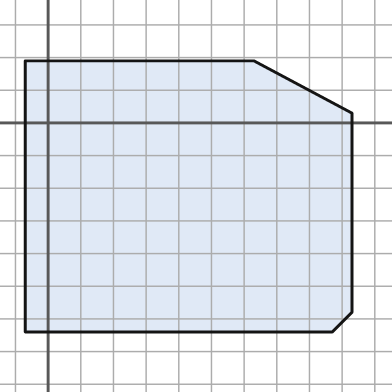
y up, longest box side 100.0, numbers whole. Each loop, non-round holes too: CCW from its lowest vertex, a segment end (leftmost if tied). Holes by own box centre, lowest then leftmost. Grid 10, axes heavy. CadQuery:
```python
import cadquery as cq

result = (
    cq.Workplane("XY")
    .moveTo(-7.0, -64.0)
    .lineTo(87.0, -64.0)
    .lineTo(93.0, -58.0)
    .lineTo(93.0, 3.0)
    .lineTo(63.0, 19.0)
    .lineTo(-7.0, 19.0)
    .close()
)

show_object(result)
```